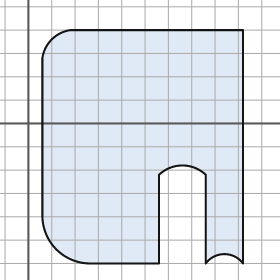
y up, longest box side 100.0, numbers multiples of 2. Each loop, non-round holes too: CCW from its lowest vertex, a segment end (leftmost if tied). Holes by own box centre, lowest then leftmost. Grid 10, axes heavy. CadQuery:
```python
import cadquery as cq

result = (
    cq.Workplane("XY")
    .moveTo(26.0, -60.0)
    .lineTo(56.0, -60.0)
    .lineTo(56.0, -22.0)
    .threePointArc((66.0, -18.0), (76.0, -22.0))
    .lineTo(76.0, -60.0)
    .threePointArc((84.0, -56.0), (92.0, -60.0))
    .lineTo(92.0, 40.0)
    .lineTo(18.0, 40.0)
    .threePointArc((10.0, 36.0), (6.0, 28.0))
    .lineTo(6.0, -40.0)
    .threePointArc((12.0, -54.0), (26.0, -60.0))
    .close()
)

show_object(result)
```